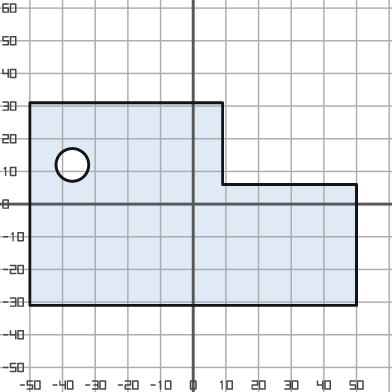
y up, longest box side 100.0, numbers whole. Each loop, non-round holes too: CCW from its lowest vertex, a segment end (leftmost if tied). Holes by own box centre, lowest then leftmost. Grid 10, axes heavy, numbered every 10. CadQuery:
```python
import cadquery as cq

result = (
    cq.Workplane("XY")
    .moveTo(-50.0, -31.0)
    .lineTo(50.0, -31.0)
    .lineTo(50.0, 6.0)
    .lineTo(9.0, 6.0)
    .lineTo(9.0, 31.0)
    .lineTo(-50.0, 31.0)
    .close()
    .moveTo(-37.0, 12.0)
    .circle(5.0)
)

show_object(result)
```